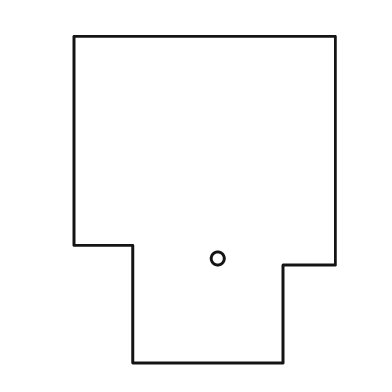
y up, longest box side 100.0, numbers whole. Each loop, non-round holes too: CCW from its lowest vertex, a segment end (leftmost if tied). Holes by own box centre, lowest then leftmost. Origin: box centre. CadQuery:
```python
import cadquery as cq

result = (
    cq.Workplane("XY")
    .moveTo(-22.0, -50.0)
    .lineTo(24.0, -50.0)
    .lineTo(24.0, -20.0)
    .lineTo(40.0, -20.0)
    .lineTo(40.0, 50.0)
    .lineTo(-40.0, 50.0)
    .lineTo(-40.0, -14.0)
    .lineTo(-22.0, -14.0)
    .close()
    .moveTo(4.0, -18.0)
    .circle(2.0)
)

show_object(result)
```